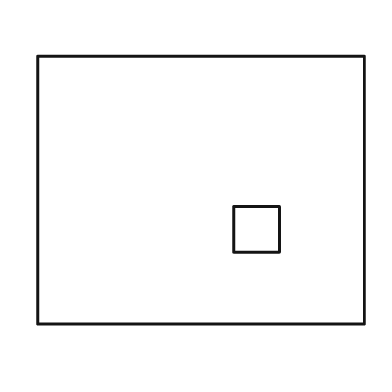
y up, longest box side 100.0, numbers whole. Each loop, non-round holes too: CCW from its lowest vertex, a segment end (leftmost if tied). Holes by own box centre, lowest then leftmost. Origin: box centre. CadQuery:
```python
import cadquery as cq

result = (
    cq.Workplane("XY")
    .moveTo(-50.0, -41.0)
    .lineTo(50.0, -41.0)
    .lineTo(50.0, 41.0)
    .lineTo(-50.0, 41.0)
    .close()
    .moveTo(10.0, -19.0)
    .lineTo(24.0, -19.0)
    .lineTo(24.0, -5.0)
    .lineTo(10.0, -5.0)
    .close()
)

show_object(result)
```